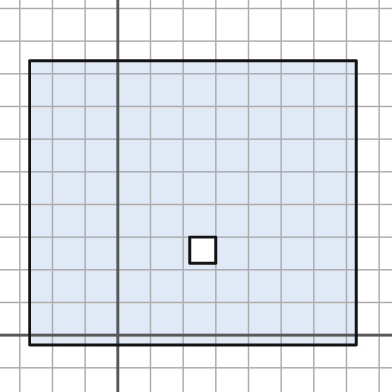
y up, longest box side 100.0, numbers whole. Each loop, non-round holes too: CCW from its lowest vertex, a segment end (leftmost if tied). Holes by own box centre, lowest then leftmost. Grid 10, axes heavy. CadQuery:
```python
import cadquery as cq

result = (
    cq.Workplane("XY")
    .moveTo(-27.0, -3.0)
    .lineTo(73.0, -3.0)
    .lineTo(73.0, 84.0)
    .lineTo(-27.0, 84.0)
    .close()
    .moveTo(22.0, 22.0)
    .lineTo(30.0, 22.0)
    .lineTo(30.0, 30.0)
    .lineTo(22.0, 30.0)
    .close()
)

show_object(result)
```